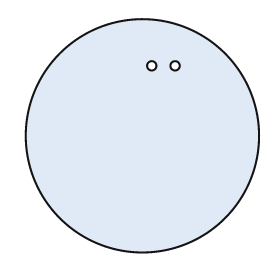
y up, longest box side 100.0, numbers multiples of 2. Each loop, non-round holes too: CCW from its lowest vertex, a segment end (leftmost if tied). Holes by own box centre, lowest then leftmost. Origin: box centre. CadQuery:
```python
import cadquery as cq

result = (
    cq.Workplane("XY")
    .moveTo(0.0, 0.0)
    .circle(50.0)
    .moveTo(4.0, 30.0)
    .circle(2.0)
    .moveTo(14.0, 30.0)
    .circle(2.0)
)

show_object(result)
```